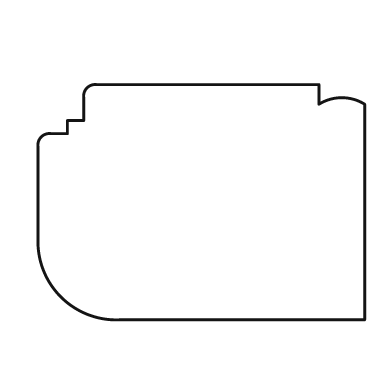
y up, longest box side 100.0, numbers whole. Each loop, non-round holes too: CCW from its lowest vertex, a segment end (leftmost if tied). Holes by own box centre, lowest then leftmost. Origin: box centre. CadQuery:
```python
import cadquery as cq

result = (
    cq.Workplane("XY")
    .moveTo(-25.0, -36.0)
    .lineTo(50.0, -36.0)
    .lineTo(50.0, 30.0)
    .threePointArc((43.0, 32.0), (36.0, 30.0))
    .lineTo(36.0, 36.0)
    .lineTo(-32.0, 36.0)
    .threePointArc((-35.0, 35.0), (-36.0, 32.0))
    .lineTo(-36.0, 25.0)
    .lineTo(-41.0, 25.0)
    .lineTo(-41.0, 21.0)
    .lineTo(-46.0, 21.0)
    .threePointArc((-49.0, 20.0), (-50.0, 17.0))
    .lineTo(-50.0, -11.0)
    .threePointArc((-43.0, -29.0), (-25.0, -36.0))
    .close()
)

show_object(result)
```